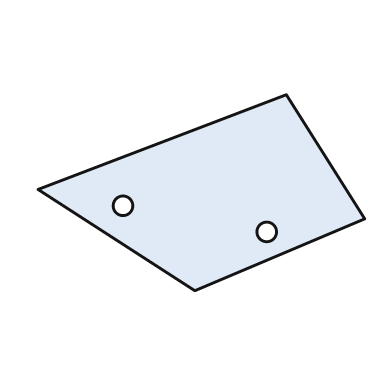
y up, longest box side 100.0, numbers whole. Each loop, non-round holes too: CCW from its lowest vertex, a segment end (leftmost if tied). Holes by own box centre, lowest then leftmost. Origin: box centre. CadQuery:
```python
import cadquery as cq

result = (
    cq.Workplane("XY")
    .moveTo(-2.0, -30.0)
    .lineTo(50.0, -8.0)
    .lineTo(26.0, 30.0)
    .lineTo(-50.0, 1.0)
    .close()
    .moveTo(20.0, -12.0)
    .circle(3.0)
    .moveTo(-24.0, -4.0)
    .circle(3.0)
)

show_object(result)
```